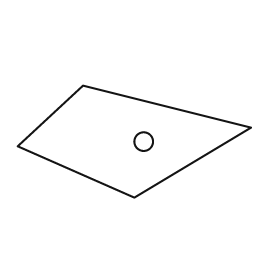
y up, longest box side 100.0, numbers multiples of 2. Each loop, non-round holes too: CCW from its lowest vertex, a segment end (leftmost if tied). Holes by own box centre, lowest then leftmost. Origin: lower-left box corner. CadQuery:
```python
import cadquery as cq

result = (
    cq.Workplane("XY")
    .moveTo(50.0, 0.0)
    .lineTo(100.0, 30.0)
    .lineTo(28.0, 48.0)
    .lineTo(0.0, 22.0)
    .close()
    .moveTo(54.0, 24.0)
    .circle(4.0)
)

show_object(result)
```